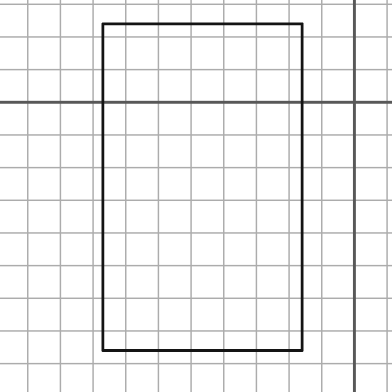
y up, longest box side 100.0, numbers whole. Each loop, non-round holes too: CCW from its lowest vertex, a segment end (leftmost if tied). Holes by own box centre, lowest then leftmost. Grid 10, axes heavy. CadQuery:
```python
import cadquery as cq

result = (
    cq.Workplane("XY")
    .moveTo(-77.0, -76.0)
    .lineTo(-16.0, -76.0)
    .lineTo(-16.0, 24.0)
    .lineTo(-77.0, 24.0)
    .close()
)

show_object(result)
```